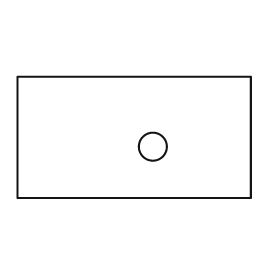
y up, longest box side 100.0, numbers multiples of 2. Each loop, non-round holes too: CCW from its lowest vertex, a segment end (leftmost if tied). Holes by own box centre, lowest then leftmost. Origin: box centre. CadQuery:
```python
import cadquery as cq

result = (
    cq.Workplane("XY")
    .moveTo(-50.0, -26.0)
    .lineTo(50.0, -26.0)
    .lineTo(50.0, 26.0)
    .lineTo(-50.0, 26.0)
    .close()
    .moveTo(8.0, -4.0)
    .circle(6.0)
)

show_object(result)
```